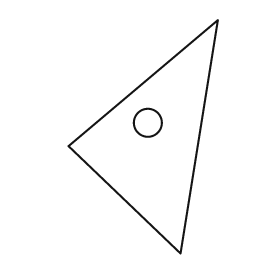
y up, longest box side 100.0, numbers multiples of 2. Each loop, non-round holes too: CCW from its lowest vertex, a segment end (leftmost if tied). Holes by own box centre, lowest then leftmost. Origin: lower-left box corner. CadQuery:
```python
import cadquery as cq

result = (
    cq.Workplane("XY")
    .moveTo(48.0, 0.0)
    .lineTo(64.0, 100.0)
    .lineTo(0.0, 46.0)
    .close()
    .moveTo(34.0, 56.0)
    .circle(6.0)
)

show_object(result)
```